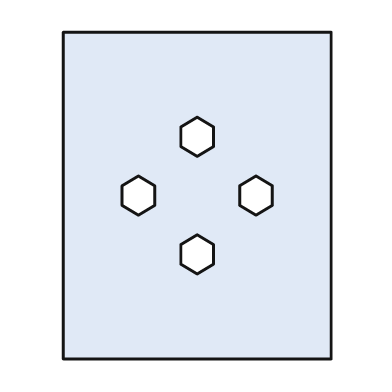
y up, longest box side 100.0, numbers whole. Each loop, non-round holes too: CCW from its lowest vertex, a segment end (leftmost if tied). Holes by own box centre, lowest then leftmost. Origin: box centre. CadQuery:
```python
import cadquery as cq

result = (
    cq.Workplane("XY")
    .moveTo(-41.0, -50.0)
    .lineTo(41.0, -50.0)
    .lineTo(41.0, 50.0)
    .lineTo(-41.0, 50.0)
    .close()
    .moveTo(0.0, -24.0)
    .lineTo(5.0, -21.0)
    .lineTo(5.0, -15.0)
    .lineTo(0.0, -12.0)
    .lineTo(-5.0, -15.0)
    .lineTo(-5.0, -21.0)
    .close()
    .moveTo(-18.0, -6.0)
    .lineTo(-13.0, -3.0)
    .lineTo(-13.0, 3.0)
    .lineTo(-18.0, 6.0)
    .lineTo(-23.0, 3.0)
    .lineTo(-23.0, -3.0)
    .close()
    .moveTo(18.0, -6.0)
    .lineTo(23.0, -3.0)
    .lineTo(23.0, 3.0)
    .lineTo(18.0, 6.0)
    .lineTo(13.0, 3.0)
    .lineTo(13.0, -3.0)
    .close()
    .moveTo(0.0, 12.0)
    .lineTo(5.0, 15.0)
    .lineTo(5.0, 21.0)
    .lineTo(0.0, 24.0)
    .lineTo(-5.0, 21.0)
    .lineTo(-5.0, 15.0)
    .close()
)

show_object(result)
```